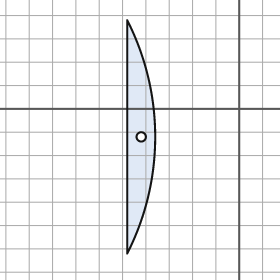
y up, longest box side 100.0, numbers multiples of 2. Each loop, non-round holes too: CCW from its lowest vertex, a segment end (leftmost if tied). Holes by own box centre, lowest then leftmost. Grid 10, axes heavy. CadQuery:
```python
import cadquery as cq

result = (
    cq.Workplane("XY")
    .moveTo(-48.0, -62.0)
    .threePointArc((-36.0, -12.0), (-48.0, 38.0))
    .close()
    .moveTo(-42.0, -12.0)
    .circle(2.0)
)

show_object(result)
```